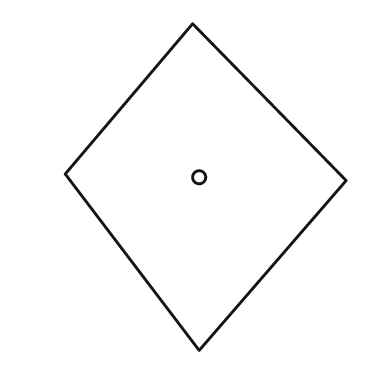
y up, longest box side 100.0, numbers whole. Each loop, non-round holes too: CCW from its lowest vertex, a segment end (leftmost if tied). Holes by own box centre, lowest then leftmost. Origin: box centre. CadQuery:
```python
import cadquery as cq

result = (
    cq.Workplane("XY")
    .moveTo(-2.0, -50.0)
    .lineTo(43.0, 2.0)
    .lineTo(-4.0, 50.0)
    .lineTo(-43.0, 4.0)
    .close()
    .moveTo(-2.0, 3.0)
    .circle(2.0)
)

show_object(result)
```